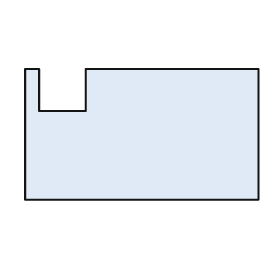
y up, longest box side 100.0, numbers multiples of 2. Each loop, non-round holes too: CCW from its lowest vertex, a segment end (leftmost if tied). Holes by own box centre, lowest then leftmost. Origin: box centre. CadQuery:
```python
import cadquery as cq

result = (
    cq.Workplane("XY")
    .moveTo(-50.0, -28.0)
    .lineTo(50.0, -28.0)
    .lineTo(50.0, 28.0)
    .lineTo(-24.0, 28.0)
    .lineTo(-24.0, 10.0)
    .lineTo(-44.0, 10.0)
    .lineTo(-44.0, 28.0)
    .lineTo(-50.0, 28.0)
    .close()
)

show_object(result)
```